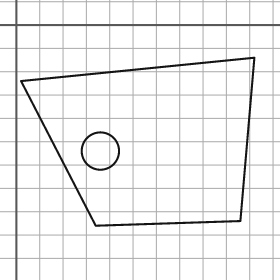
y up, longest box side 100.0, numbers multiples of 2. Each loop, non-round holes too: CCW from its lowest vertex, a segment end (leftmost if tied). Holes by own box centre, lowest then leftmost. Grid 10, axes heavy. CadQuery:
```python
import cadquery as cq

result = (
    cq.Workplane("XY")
    .moveTo(34.0, -86.0)
    .lineTo(96.0, -84.0)
    .lineTo(102.0, -14.0)
    .lineTo(2.0, -24.0)
    .close()
    .moveTo(36.0, -54.0)
    .circle(8.0)
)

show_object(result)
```